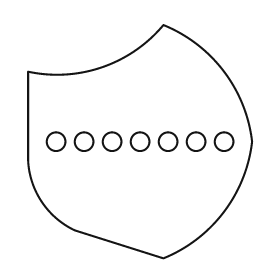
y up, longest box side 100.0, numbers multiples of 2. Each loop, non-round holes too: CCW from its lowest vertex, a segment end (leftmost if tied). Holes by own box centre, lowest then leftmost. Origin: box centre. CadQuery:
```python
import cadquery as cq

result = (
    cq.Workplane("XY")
    .moveTo(10.0, -50.0)
    .threePointArc((36.0, -30.0), (48.0, 0.0))
    .threePointArc((36.0, 30.0), (10.0, 50.0))
    .threePointArc((-16.0, 32.0), (-48.0, 30.0))
    .lineTo(-48.0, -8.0)
    .threePointArc((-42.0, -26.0), (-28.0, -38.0))
    .close()
    .moveTo(-36.0, 0.0)
    .circle(4.0)
    .moveTo(-24.0, 0.0)
    .circle(4.0)
    .moveTo(-12.0, 0.0)
    .circle(4.0)
    .moveTo(0.0, 0.0)
    .circle(4.0)
    .moveTo(12.0, 0.0)
    .circle(4.0)
    .moveTo(24.0, 0.0)
    .circle(4.0)
    .moveTo(36.0, 0.0)
    .circle(4.0)
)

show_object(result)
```